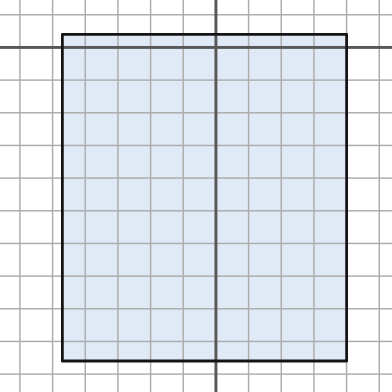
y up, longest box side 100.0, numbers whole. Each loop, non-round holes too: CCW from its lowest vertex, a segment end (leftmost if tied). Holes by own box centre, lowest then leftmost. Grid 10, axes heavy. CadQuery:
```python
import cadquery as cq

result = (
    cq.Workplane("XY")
    .moveTo(-47.0, -96.0)
    .lineTo(40.0, -96.0)
    .lineTo(40.0, 4.0)
    .lineTo(-47.0, 4.0)
    .close()
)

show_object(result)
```